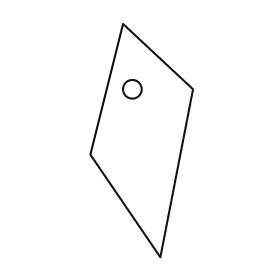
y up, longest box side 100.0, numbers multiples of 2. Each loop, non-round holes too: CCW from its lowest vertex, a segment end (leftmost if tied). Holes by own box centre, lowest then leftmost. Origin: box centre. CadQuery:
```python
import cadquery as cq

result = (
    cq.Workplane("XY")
    .moveTo(8.0, -50.0)
    .lineTo(22.0, 22.0)
    .lineTo(-8.0, 50.0)
    .lineTo(-22.0, -6.0)
    .close()
    .moveTo(-4.0, 22.0)
    .circle(4.0)
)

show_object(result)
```